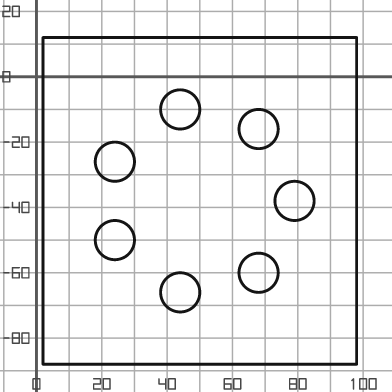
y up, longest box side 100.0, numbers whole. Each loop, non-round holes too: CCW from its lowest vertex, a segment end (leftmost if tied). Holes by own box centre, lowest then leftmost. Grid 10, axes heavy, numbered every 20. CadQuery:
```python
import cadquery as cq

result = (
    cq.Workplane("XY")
    .moveTo(2.0, -88.0)
    .lineTo(98.0, -88.0)
    .lineTo(98.0, 12.0)
    .lineTo(2.0, 12.0)
    .close()
    .moveTo(44.0, -66.0)
    .circle(6.0)
    .moveTo(68.0, -60.0)
    .circle(6.0)
    .moveTo(24.0, -50.0)
    .circle(6.0)
    .moveTo(79.0, -38.0)
    .circle(6.0)
    .moveTo(24.0, -26.0)
    .circle(6.0)
    .moveTo(68.0, -16.0)
    .circle(6.0)
    .moveTo(44.0, -10.0)
    .circle(6.0)
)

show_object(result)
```